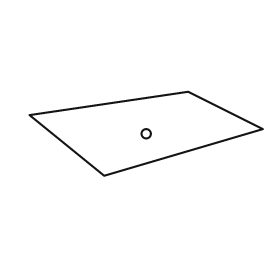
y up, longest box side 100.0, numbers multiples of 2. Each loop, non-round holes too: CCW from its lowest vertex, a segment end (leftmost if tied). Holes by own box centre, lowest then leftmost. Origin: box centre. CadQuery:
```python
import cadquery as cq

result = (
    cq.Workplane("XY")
    .moveTo(-18.0, -18.0)
    .lineTo(50.0, 2.0)
    .lineTo(18.0, 18.0)
    .lineTo(-50.0, 8.0)
    .close()
    .moveTo(0.0, 0.0)
    .circle(2.0)
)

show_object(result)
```